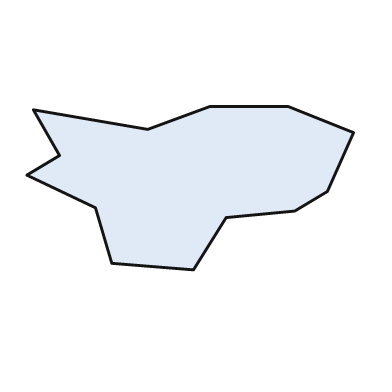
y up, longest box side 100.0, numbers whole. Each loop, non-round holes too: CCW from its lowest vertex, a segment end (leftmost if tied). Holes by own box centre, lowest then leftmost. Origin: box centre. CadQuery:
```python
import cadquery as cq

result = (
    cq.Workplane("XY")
    .moveTo(1.0, -25.0)
    .lineTo(11.0, -9.0)
    .lineTo(32.0, -7.0)
    .lineTo(42.0, -1.0)
    .lineTo(50.0, 17.0)
    .lineTo(30.0, 25.0)
    .lineTo(6.0, 25.0)
    .lineTo(-13.0, 18.0)
    .lineTo(-48.0, 24.0)
    .lineTo(-40.0, 10.0)
    .lineTo(-50.0, 4.0)
    .lineTo(-29.0, -6.0)
    .lineTo(-24.0, -23.0)
    .close()
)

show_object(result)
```